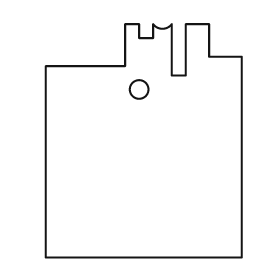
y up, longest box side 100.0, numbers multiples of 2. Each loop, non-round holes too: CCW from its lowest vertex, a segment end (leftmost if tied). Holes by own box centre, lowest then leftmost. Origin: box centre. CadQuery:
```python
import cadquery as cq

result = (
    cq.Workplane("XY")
    .moveTo(-42.0, -50.0)
    .lineTo(42.0, -50.0)
    .lineTo(42.0, 36.0)
    .lineTo(28.0, 36.0)
    .lineTo(28.0, 50.0)
    .lineTo(18.0, 50.0)
    .lineTo(18.0, 28.0)
    .lineTo(12.0, 28.0)
    .lineTo(12.0, 50.0)
    .threePointArc((8.0, 48.0), (4.0, 50.0))
    .lineTo(4.0, 44.0)
    .lineTo(-2.0, 44.0)
    .lineTo(-2.0, 50.0)
    .lineTo(-8.0, 50.0)
    .lineTo(-8.0, 32.0)
    .lineTo(-42.0, 32.0)
    .close()
    .moveTo(-2.0, 22.0)
    .circle(4.0)
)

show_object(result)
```